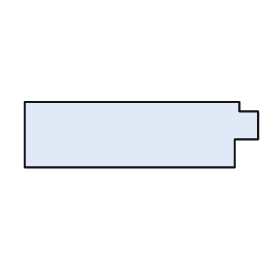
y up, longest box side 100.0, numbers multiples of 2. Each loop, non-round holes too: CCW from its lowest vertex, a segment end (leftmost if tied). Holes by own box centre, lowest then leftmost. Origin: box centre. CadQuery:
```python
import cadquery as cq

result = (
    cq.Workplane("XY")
    .moveTo(-50.0, -14.0)
    .lineTo(40.0, -14.0)
    .lineTo(40.0, -2.0)
    .lineTo(50.0, -2.0)
    .lineTo(50.0, 10.0)
    .lineTo(42.0, 10.0)
    .lineTo(42.0, 14.0)
    .lineTo(-50.0, 14.0)
    .close()
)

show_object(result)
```